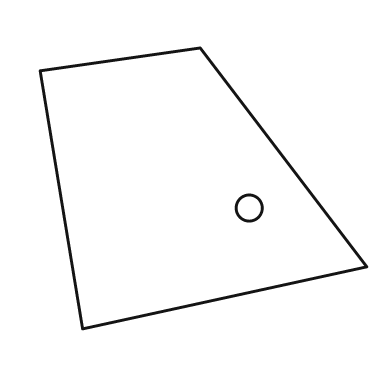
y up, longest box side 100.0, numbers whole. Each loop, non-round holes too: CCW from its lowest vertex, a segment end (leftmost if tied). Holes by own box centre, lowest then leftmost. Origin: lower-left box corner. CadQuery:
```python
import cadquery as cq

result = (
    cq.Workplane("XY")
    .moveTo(13.0, 0.0)
    .lineTo(100.0, 19.0)
    .lineTo(49.0, 86.0)
    .lineTo(0.0, 79.0)
    .close()
    .moveTo(64.0, 37.0)
    .circle(4.0)
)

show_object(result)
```